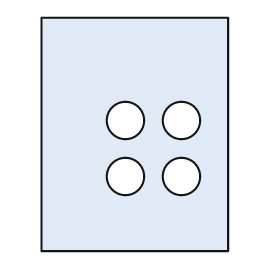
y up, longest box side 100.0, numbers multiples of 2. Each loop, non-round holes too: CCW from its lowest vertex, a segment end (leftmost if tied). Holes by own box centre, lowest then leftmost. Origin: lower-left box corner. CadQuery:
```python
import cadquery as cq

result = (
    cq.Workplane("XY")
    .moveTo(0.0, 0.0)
    .lineTo(80.0, 0.0)
    .lineTo(80.0, 100.0)
    .lineTo(0.0, 100.0)
    .close()
    .moveTo(36.0, 32.0)
    .circle(8.0)
    .moveTo(60.0, 32.0)
    .circle(8.0)
    .moveTo(36.0, 56.0)
    .circle(8.0)
    .moveTo(60.0, 56.0)
    .circle(8.0)
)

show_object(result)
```